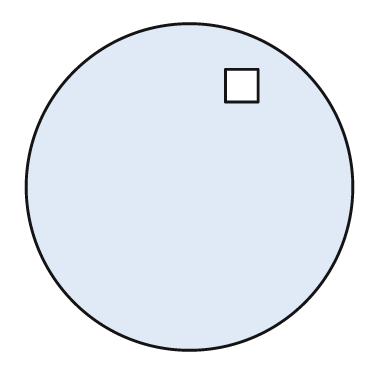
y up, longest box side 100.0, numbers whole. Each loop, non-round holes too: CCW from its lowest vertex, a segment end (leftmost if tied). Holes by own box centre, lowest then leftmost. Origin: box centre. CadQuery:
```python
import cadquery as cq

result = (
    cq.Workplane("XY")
    .moveTo(0.0, 0.0)
    .circle(50.0)
    .moveTo(11.0, 26.0)
    .lineTo(21.0, 26.0)
    .lineTo(21.0, 36.0)
    .lineTo(11.0, 36.0)
    .close()
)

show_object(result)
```